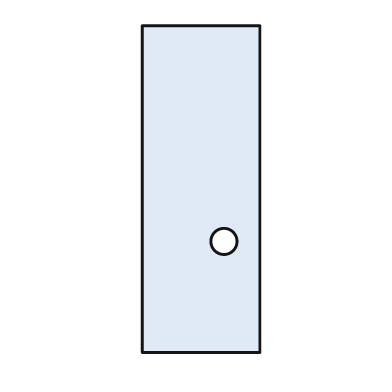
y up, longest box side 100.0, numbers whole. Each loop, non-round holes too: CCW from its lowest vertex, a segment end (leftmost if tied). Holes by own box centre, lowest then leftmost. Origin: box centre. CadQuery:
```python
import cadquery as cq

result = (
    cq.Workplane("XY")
    .moveTo(-18.0, -50.0)
    .lineTo(18.0, -50.0)
    .lineTo(18.0, 50.0)
    .lineTo(-18.0, 50.0)
    .close()
    .moveTo(7.0, -16.0)
    .circle(4.0)
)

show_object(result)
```